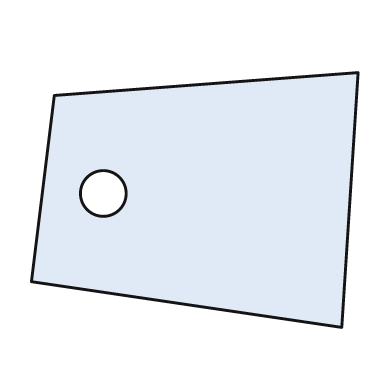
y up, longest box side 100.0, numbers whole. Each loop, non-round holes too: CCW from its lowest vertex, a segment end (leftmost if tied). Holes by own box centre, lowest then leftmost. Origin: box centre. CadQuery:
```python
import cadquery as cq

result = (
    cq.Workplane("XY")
    .moveTo(45.0, -39.0)
    .lineTo(50.0, 39.0)
    .lineTo(-43.0, 32.0)
    .lineTo(-50.0, -25.0)
    .close()
    .moveTo(-28.0, 2.0)
    .circle(7.0)
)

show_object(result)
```